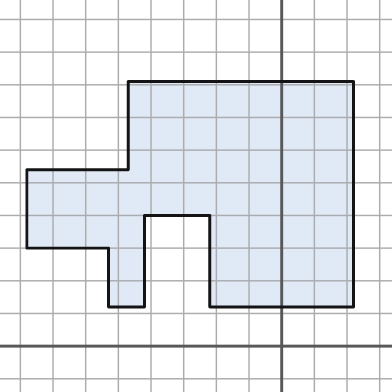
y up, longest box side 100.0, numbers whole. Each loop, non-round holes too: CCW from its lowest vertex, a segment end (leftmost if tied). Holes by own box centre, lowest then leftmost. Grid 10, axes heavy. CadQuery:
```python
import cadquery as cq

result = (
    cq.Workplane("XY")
    .moveTo(-53.0, 12.0)
    .lineTo(-42.0, 12.0)
    .lineTo(-42.0, 40.0)
    .lineTo(-22.0, 40.0)
    .lineTo(-22.0, 12.0)
    .lineTo(22.0, 12.0)
    .lineTo(22.0, 81.0)
    .lineTo(-47.0, 81.0)
    .lineTo(-47.0, 54.0)
    .lineTo(-78.0, 54.0)
    .lineTo(-78.0, 30.0)
    .lineTo(-53.0, 30.0)
    .close()
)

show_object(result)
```